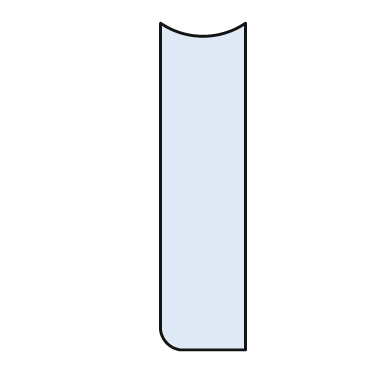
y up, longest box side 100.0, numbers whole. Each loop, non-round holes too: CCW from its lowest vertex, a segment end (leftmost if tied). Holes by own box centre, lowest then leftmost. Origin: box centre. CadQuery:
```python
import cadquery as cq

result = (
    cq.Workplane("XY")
    .moveTo(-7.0, -50.0)
    .lineTo(13.0, -50.0)
    .lineTo(13.0, 50.0)
    .threePointArc((0.0, 46.0), (-13.0, 50.0))
    .lineTo(-13.0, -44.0)
    .threePointArc((-11.0, -48.0), (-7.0, -50.0))
    .close()
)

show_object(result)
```